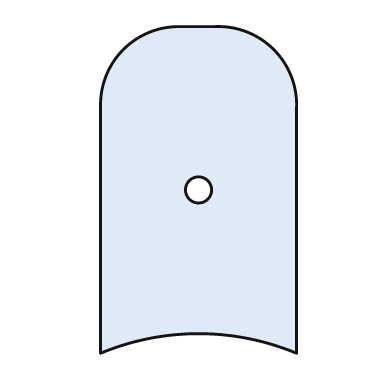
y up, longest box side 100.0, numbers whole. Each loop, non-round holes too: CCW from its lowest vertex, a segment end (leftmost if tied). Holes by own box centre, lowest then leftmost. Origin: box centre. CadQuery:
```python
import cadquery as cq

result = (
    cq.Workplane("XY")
    .moveTo(-30.0, -50.0)
    .threePointArc((0.0, -44.0), (30.0, -50.0))
    .lineTo(30.0, 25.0)
    .threePointArc((23.0, 43.0), (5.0, 50.0))
    .lineTo(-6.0, 50.0)
    .threePointArc((-23.0, 43.0), (-30.0, 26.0))
    .close()
    .moveTo(0.0, 0.0)
    .circle(4.0)
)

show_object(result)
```